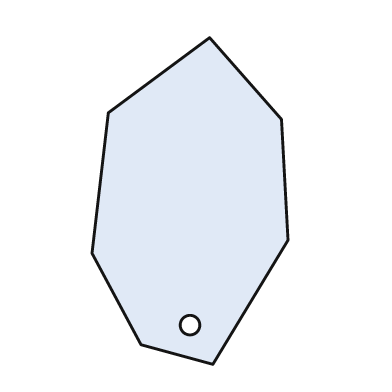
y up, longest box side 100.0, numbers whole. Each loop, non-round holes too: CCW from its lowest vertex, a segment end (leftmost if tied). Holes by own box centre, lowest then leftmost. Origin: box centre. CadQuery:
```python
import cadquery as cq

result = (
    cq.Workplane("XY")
    .moveTo(7.0, -50.0)
    .lineTo(30.0, -12.0)
    .lineTo(28.0, 25.0)
    .lineTo(6.0, 50.0)
    .lineTo(-25.0, 27.0)
    .lineTo(-30.0, -16.0)
    .lineTo(-15.0, -44.0)
    .close()
    .moveTo(0.0, -38.0)
    .circle(3.0)
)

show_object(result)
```